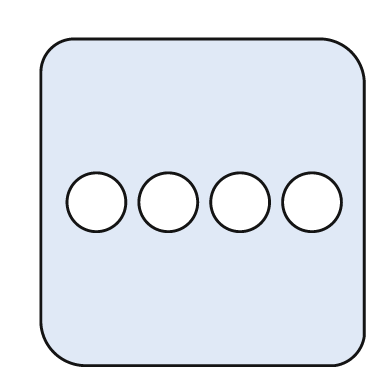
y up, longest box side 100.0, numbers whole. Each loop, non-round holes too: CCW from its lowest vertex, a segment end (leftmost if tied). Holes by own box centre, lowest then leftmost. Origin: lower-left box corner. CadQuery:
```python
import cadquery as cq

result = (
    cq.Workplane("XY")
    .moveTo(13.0, 0.0)
    .lineTo(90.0, 0.0)
    .threePointArc((96.0, 3.0), (99.0, 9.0))
    .lineTo(99.0, 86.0)
    .threePointArc((95.0, 96.0), (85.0, 100.0))
    .lineTo(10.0, 100.0)
    .threePointArc((3.0, 97.0), (0.0, 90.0))
    .lineTo(0.0, 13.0)
    .threePointArc((4.0, 4.0), (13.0, 0.0))
    .close()
    .moveTo(17.0, 50.0)
    .circle(9.0)
    .moveTo(39.0, 50.0)
    .circle(9.0)
    .moveTo(61.0, 50.0)
    .circle(9.0)
    .moveTo(83.0, 50.0)
    .circle(9.0)
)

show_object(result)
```